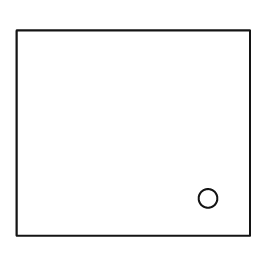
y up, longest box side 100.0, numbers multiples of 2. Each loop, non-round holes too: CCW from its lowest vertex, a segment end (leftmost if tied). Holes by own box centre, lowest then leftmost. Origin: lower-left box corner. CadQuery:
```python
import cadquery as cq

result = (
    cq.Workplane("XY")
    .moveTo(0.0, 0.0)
    .lineTo(100.0, 0.0)
    .lineTo(100.0, 88.0)
    .lineTo(0.0, 88.0)
    .close()
    .moveTo(82.0, 16.0)
    .circle(4.0)
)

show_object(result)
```